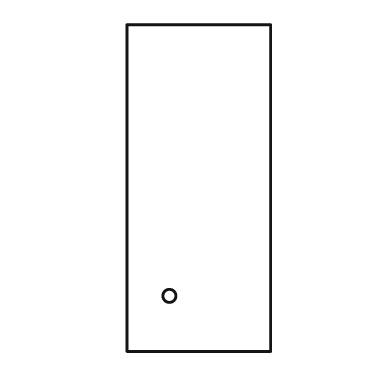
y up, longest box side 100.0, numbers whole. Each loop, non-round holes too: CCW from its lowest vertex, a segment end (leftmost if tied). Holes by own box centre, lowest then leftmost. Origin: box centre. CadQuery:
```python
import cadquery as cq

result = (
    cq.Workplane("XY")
    .moveTo(-22.0, -50.0)
    .lineTo(22.0, -50.0)
    .lineTo(22.0, 50.0)
    .lineTo(-22.0, 50.0)
    .close()
    .moveTo(-9.0, -33.0)
    .circle(2.0)
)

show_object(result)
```